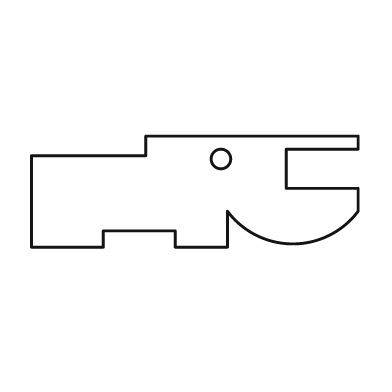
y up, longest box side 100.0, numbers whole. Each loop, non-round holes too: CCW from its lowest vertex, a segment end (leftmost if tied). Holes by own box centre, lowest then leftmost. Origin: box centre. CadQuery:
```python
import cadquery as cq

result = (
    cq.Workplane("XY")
    .moveTo(-50.0, -17.0)
    .lineTo(-28.0, -17.0)
    .lineTo(-28.0, -12.0)
    .lineTo(-6.0, -12.0)
    .lineTo(-6.0, -17.0)
    .lineTo(10.0, -17.0)
    .lineTo(10.0, -6.0)
    .threePointArc((30.0, -16.0), (50.0, -6.0))
    .lineTo(50.0, 1.0)
    .lineTo(28.0, 1.0)
    .lineTo(28.0, 13.0)
    .lineTo(50.0, 13.0)
    .lineTo(50.0, 17.0)
    .lineTo(-15.0, 17.0)
    .lineTo(-15.0, 11.0)
    .lineTo(-50.0, 11.0)
    .close()
    .moveTo(8.0, 10.0)
    .circle(3.0)
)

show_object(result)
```